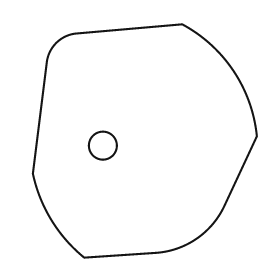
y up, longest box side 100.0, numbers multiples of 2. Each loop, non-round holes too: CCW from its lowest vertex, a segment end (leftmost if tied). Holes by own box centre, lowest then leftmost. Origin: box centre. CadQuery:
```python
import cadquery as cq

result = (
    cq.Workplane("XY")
    .moveTo(-26.0, -50.0)
    .lineTo(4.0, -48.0)
    .threePointArc((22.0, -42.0), (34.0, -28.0))
    .lineTo(48.0, 2.0)
    .threePointArc((38.0, 30.0), (16.0, 50.0))
    .lineTo(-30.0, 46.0)
    .threePointArc((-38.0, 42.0), (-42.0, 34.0))
    .lineTo(-48.0, -14.0)
    .threePointArc((-40.0, -34.0), (-26.0, -50.0))
    .close()
    .moveTo(-18.0, -2.0)
    .circle(6.0)
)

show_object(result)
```